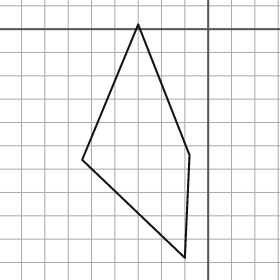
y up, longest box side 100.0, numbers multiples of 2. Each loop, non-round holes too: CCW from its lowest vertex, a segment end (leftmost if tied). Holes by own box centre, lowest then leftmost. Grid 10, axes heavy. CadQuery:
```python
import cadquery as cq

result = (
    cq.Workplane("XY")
    .moveTo(-10.0, -98.0)
    .lineTo(-8.0, -54.0)
    .lineTo(-30.0, 2.0)
    .lineTo(-54.0, -56.0)
    .close()
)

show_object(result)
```